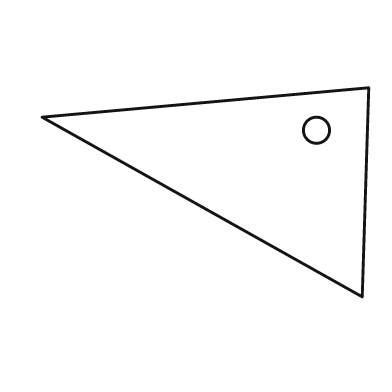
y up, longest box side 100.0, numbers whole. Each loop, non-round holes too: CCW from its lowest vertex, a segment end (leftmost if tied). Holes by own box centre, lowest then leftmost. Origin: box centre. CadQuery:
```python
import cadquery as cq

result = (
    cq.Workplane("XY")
    .moveTo(48.0, -32.0)
    .lineTo(50.0, 32.0)
    .lineTo(-50.0, 23.0)
    .close()
    .moveTo(34.0, 19.0)
    .circle(4.0)
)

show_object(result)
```